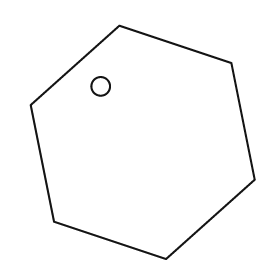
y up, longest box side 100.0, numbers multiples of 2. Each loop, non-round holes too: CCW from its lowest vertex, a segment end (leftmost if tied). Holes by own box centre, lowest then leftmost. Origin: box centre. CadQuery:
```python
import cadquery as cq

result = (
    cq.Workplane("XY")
    .moveTo(10.0, -50.0)
    .lineTo(48.0, -16.0)
    .lineTo(38.0, 34.0)
    .lineTo(-10.0, 50.0)
    .lineTo(-48.0, 16.0)
    .lineTo(-38.0, -34.0)
    .close()
    .moveTo(-18.0, 24.0)
    .circle(4.0)
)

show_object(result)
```